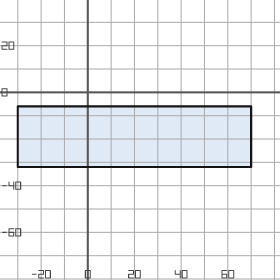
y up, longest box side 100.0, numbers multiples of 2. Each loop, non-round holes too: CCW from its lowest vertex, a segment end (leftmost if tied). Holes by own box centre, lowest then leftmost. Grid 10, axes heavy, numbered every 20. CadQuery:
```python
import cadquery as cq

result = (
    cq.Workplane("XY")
    .moveTo(-30.0, -32.0)
    .lineTo(70.0, -32.0)
    .lineTo(70.0, -6.0)
    .lineTo(-30.0, -6.0)
    .close()
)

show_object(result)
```